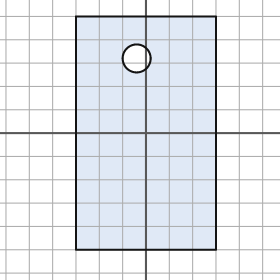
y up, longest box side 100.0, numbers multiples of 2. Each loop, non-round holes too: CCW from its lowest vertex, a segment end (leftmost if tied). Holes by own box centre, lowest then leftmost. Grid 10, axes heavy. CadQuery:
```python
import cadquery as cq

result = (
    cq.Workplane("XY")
    .moveTo(-30.0, -50.0)
    .lineTo(30.0, -50.0)
    .lineTo(30.0, 50.0)
    .lineTo(-30.0, 50.0)
    .close()
    .moveTo(-4.0, 32.0)
    .circle(6.0)
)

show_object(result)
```